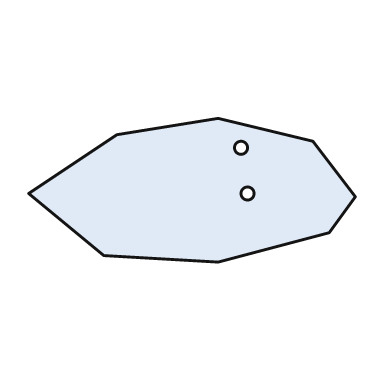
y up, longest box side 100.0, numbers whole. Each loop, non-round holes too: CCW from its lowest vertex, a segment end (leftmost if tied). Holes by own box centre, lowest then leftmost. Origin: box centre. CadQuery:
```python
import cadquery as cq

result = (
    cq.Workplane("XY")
    .moveTo(8.0, -22.0)
    .lineTo(42.0, -13.0)
    .lineTo(50.0, -2.0)
    .lineTo(37.0, 15.0)
    .lineTo(8.0, 22.0)
    .lineTo(-23.0, 17.0)
    .lineTo(-50.0, -1.0)
    .lineTo(-27.0, -20.0)
    .close()
    .moveTo(17.0, -1.0)
    .circle(2.0)
    .moveTo(15.0, 13.0)
    .circle(2.0)
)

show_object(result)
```